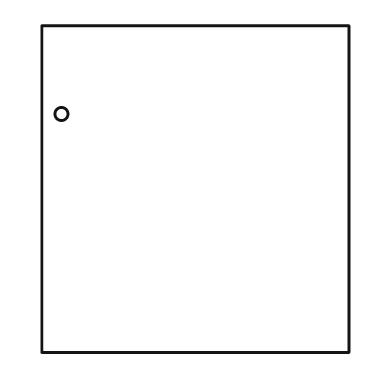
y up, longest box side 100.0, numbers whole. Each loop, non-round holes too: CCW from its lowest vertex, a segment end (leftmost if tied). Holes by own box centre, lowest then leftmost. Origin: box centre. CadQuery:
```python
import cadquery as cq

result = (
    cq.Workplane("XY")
    .moveTo(-47.0, -50.0)
    .lineTo(47.0, -50.0)
    .lineTo(47.0, 50.0)
    .lineTo(-47.0, 50.0)
    .close()
    .moveTo(-41.0, 23.0)
    .circle(2.0)
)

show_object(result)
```